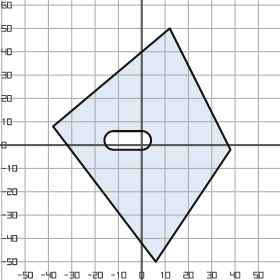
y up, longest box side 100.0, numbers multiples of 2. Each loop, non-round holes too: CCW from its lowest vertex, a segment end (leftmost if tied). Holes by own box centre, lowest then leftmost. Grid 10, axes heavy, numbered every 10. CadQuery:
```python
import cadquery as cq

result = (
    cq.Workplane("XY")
    .moveTo(6.0, -50.0)
    .lineTo(38.0, -2.0)
    .lineTo(12.0, 50.0)
    .lineTo(-38.0, 8.0)
    .close()
    .moveTo(-12.0, -2.0)
    .lineTo(0.0, -2.0)
    .threePointArc((4.0, 2.0), (0.0, 6.0))
    .lineTo(-12.0, 6.0)
    .threePointArc((-16.0, 2.0), (-12.0, -2.0))
    .close()
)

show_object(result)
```